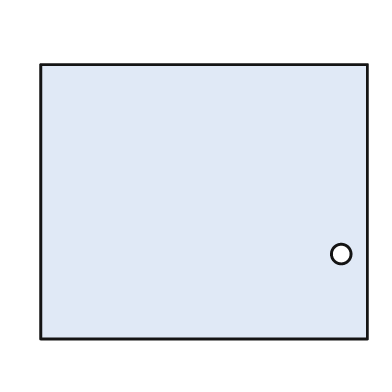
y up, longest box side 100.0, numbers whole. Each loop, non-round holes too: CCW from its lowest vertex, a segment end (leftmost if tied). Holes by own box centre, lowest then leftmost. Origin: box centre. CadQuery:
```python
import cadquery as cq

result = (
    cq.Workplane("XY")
    .moveTo(-50.0, -42.0)
    .lineTo(50.0, -42.0)
    .lineTo(50.0, 42.0)
    .lineTo(-50.0, 42.0)
    .close()
    .moveTo(42.0, -16.0)
    .circle(3.0)
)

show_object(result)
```